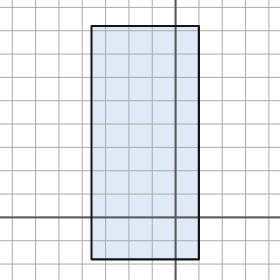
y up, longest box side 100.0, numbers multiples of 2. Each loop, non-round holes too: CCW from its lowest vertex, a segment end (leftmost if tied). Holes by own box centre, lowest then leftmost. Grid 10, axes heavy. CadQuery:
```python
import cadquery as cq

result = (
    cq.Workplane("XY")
    .moveTo(-36.0, -18.0)
    .lineTo(10.0, -18.0)
    .lineTo(10.0, 82.0)
    .lineTo(-36.0, 82.0)
    .close()
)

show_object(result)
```